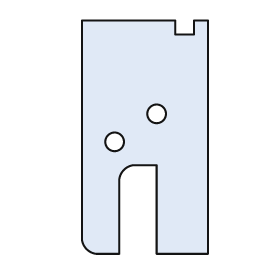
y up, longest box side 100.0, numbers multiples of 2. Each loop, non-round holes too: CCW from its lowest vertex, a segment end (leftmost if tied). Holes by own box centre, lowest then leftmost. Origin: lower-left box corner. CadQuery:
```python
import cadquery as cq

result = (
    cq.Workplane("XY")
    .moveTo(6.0, 0.0)
    .lineTo(16.0, 0.0)
    .lineTo(16.0, 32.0)
    .threePointArc((18.0, 36.0), (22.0, 38.0))
    .lineTo(32.0, 38.0)
    .lineTo(32.0, 0.0)
    .lineTo(54.0, 0.0)
    .lineTo(54.0, 100.0)
    .lineTo(48.0, 100.0)
    .lineTo(48.0, 94.0)
    .lineTo(40.0, 94.0)
    .lineTo(40.0, 100.0)
    .lineTo(0.0, 100.0)
    .lineTo(0.0, 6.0)
    .threePointArc((2.0, 2.0), (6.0, 0.0))
    .close()
    .moveTo(14.0, 48.0)
    .circle(4.0)
    .moveTo(32.0, 60.0)
    .circle(4.0)
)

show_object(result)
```